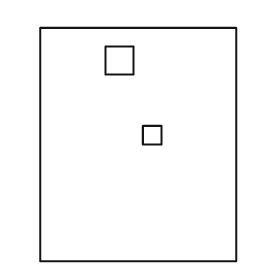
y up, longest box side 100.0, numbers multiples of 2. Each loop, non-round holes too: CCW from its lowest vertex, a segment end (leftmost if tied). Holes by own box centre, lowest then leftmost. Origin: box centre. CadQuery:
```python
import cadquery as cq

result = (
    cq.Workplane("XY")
    .moveTo(-42.0, -50.0)
    .lineTo(42.0, -50.0)
    .lineTo(42.0, 50.0)
    .lineTo(-42.0, 50.0)
    .close()
    .moveTo(2.0, 0.0)
    .lineTo(10.0, 0.0)
    .lineTo(10.0, 8.0)
    .lineTo(2.0, 8.0)
    .close()
    .moveTo(-14.0, 30.0)
    .lineTo(-2.0, 30.0)
    .lineTo(-2.0, 42.0)
    .lineTo(-14.0, 42.0)
    .close()
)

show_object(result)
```